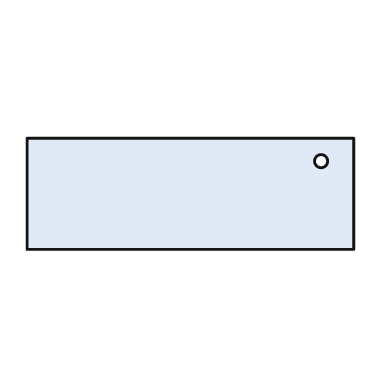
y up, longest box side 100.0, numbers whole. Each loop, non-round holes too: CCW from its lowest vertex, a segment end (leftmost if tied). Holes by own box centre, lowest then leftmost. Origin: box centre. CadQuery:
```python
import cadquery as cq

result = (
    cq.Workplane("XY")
    .moveTo(-50.0, -17.0)
    .lineTo(50.0, -17.0)
    .lineTo(50.0, 17.0)
    .lineTo(-50.0, 17.0)
    .close()
    .moveTo(40.0, 10.0)
    .circle(2.0)
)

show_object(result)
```